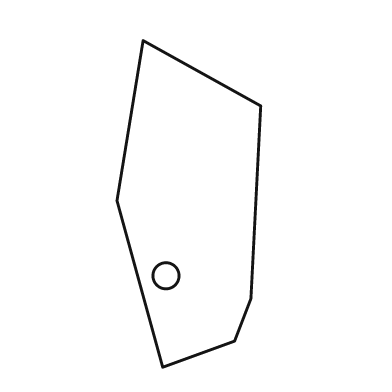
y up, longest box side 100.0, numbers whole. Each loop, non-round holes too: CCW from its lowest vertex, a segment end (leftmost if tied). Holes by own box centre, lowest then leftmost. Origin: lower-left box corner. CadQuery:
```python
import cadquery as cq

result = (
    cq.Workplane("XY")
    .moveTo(14.0, 0.0)
    .lineTo(36.0, 8.0)
    .lineTo(41.0, 21.0)
    .lineTo(44.0, 80.0)
    .lineTo(8.0, 100.0)
    .lineTo(0.0, 51.0)
    .close()
    .moveTo(15.0, 28.0)
    .circle(4.0)
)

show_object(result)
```